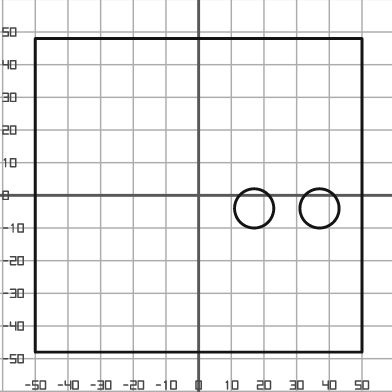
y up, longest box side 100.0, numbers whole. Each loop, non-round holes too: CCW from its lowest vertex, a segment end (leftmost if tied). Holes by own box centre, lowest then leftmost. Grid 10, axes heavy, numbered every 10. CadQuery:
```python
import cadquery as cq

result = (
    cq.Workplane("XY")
    .moveTo(-50.0, -48.0)
    .lineTo(50.0, -48.0)
    .lineTo(50.0, 48.0)
    .lineTo(-50.0, 48.0)
    .close()
    .moveTo(17.0, -4.0)
    .circle(6.0)
    .moveTo(37.0, -4.0)
    .circle(6.0)
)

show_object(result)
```